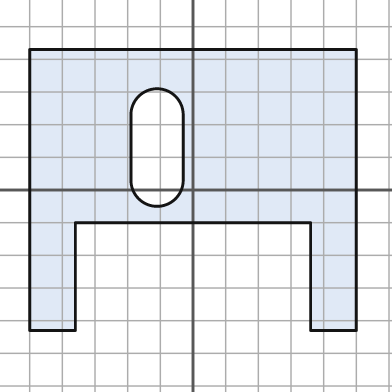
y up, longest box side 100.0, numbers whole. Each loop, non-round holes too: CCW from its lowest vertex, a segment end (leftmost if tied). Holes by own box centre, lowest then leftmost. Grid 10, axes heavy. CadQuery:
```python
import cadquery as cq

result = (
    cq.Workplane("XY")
    .moveTo(-50.0, -43.0)
    .lineTo(-36.0, -43.0)
    .lineTo(-36.0, -10.0)
    .lineTo(36.0, -10.0)
    .lineTo(36.0, -43.0)
    .lineTo(50.0, -43.0)
    .lineTo(50.0, 43.0)
    .lineTo(-50.0, 43.0)
    .close()
    .moveTo(-19.0, 3.0)
    .threePointArc((-11.0, -5.0), (-3.0, 3.0))
    .lineTo(-3.0, 23.0)
    .threePointArc((-11.0, 31.0), (-19.0, 23.0))
    .close()
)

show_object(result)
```